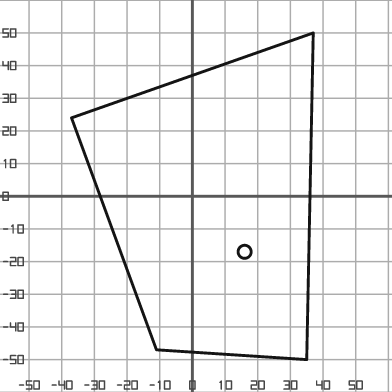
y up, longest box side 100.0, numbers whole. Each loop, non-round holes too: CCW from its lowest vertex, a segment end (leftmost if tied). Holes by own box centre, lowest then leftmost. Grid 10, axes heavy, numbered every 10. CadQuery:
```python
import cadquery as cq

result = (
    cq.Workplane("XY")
    .moveTo(35.0, -50.0)
    .lineTo(37.0, 50.0)
    .lineTo(-37.0, 24.0)
    .lineTo(-11.0, -47.0)
    .close()
    .moveTo(16.0, -17.0)
    .circle(2.0)
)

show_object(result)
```